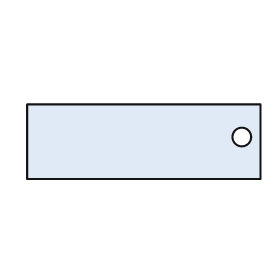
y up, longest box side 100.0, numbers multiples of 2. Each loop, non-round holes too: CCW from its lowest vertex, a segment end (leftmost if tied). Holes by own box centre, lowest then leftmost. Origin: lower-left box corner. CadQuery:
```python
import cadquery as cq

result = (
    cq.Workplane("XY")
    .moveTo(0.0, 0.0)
    .lineTo(100.0, 0.0)
    .lineTo(100.0, 32.0)
    .lineTo(0.0, 32.0)
    .close()
    .moveTo(92.0, 18.0)
    .circle(4.0)
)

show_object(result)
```